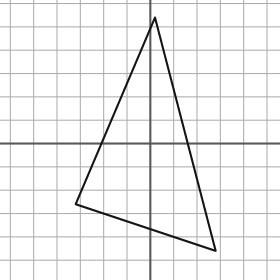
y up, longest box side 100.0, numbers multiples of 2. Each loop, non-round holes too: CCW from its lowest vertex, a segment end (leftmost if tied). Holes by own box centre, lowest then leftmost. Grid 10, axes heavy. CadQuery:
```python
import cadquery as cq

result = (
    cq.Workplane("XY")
    .moveTo(28.0, -46.0)
    .lineTo(2.0, 54.0)
    .lineTo(-32.0, -26.0)
    .close()
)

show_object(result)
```